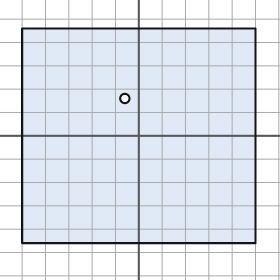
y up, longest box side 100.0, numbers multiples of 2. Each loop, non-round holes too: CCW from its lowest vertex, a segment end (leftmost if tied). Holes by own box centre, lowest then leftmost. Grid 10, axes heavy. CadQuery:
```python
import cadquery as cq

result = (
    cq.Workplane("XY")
    .moveTo(-50.0, -46.0)
    .lineTo(50.0, -46.0)
    .lineTo(50.0, 46.0)
    .lineTo(-50.0, 46.0)
    .close()
    .moveTo(-6.0, 16.0)
    .circle(2.0)
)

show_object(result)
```